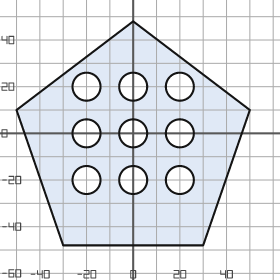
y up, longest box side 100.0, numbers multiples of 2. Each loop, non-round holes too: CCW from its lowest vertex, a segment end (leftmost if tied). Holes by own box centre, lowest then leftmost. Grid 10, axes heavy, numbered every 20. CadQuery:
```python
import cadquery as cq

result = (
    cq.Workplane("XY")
    .moveTo(-30.0, -48.0)
    .lineTo(30.0, -48.0)
    .lineTo(50.0, 10.0)
    .lineTo(0.0, 48.0)
    .lineTo(-50.0, 10.0)
    .close()
    .moveTo(-20.0, -20.0)
    .circle(6.0)
    .moveTo(0.0, -20.0)
    .circle(6.0)
    .moveTo(20.0, -20.0)
    .circle(6.0)
    .moveTo(-20.0, 0.0)
    .circle(6.0)
    .moveTo(0.0, 0.0)
    .circle(6.0)
    .moveTo(20.0, 0.0)
    .circle(6.0)
    .moveTo(-20.0, 20.0)
    .circle(6.0)
    .moveTo(0.0, 20.0)
    .circle(6.0)
    .moveTo(20.0, 20.0)
    .circle(6.0)
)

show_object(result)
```